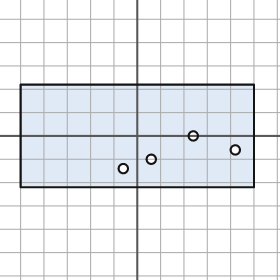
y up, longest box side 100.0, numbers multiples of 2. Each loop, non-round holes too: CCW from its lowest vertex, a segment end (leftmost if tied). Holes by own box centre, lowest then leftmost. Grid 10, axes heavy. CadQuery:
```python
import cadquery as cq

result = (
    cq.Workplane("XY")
    .moveTo(-50.0, -22.0)
    .lineTo(50.0, -22.0)
    .lineTo(50.0, 22.0)
    .lineTo(-50.0, 22.0)
    .close()
    .moveTo(-6.0, -14.0)
    .circle(2.0)
    .moveTo(6.0, -10.0)
    .circle(2.0)
    .moveTo(42.0, -6.0)
    .circle(2.0)
    .moveTo(24.0, 0.0)
    .circle(2.0)
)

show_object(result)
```